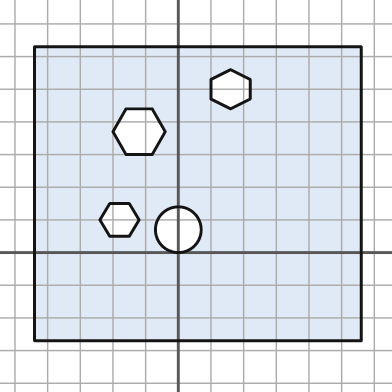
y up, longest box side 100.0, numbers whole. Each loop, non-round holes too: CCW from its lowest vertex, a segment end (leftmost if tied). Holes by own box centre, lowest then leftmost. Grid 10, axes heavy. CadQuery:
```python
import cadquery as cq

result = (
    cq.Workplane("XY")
    .moveTo(-44.0, -27.0)
    .lineTo(56.0, -27.0)
    .lineTo(56.0, 63.0)
    .lineTo(-44.0, 63.0)
    .close()
    .moveTo(0.0, 7.0)
    .circle(7.0)
    .moveTo(-21.0, 5.0)
    .lineTo(-15.0, 5.0)
    .lineTo(-12.0, 10.0)
    .lineTo(-15.0, 15.0)
    .lineTo(-21.0, 15.0)
    .lineTo(-24.0, 10.0)
    .close()
    .moveTo(-16.0, 30.0)
    .lineTo(-8.0, 30.0)
    .lineTo(-4.0, 37.0)
    .lineTo(-8.0, 44.0)
    .lineTo(-16.0, 44.0)
    .lineTo(-20.0, 37.0)
    .close()
    .moveTo(16.0, 44.0)
    .lineTo(22.0, 47.0)
    .lineTo(22.0, 53.0)
    .lineTo(16.0, 56.0)
    .lineTo(10.0, 53.0)
    .lineTo(10.0, 47.0)
    .close()
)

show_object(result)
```